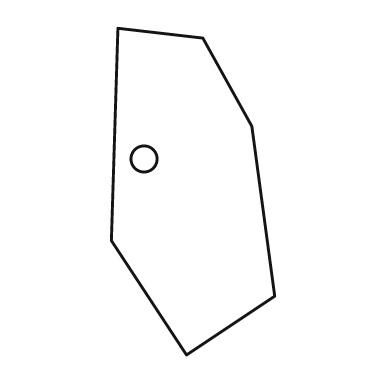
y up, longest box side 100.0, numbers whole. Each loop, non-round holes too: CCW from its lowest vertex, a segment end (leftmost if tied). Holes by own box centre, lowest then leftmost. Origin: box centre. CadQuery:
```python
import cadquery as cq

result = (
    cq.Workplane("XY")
    .moveTo(-2.0, -50.0)
    .lineTo(25.0, -32.0)
    .lineTo(18.0, 20.0)
    .lineTo(3.0, 47.0)
    .lineTo(-23.0, 50.0)
    .lineTo(-25.0, -15.0)
    .close()
    .moveTo(-15.0, 10.0)
    .circle(4.0)
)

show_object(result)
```